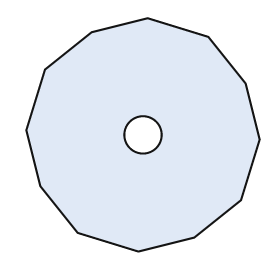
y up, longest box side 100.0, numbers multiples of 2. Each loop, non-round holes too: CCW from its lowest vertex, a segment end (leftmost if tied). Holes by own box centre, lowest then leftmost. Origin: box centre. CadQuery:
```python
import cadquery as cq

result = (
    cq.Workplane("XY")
    .moveTo(-2.0, -50.0)
    .lineTo(22.0, -44.0)
    .lineTo(42.0, -28.0)
    .lineTo(50.0, -2.0)
    .lineTo(44.0, 22.0)
    .lineTo(28.0, 42.0)
    .lineTo(2.0, 50.0)
    .lineTo(-22.0, 44.0)
    .lineTo(-42.0, 28.0)
    .lineTo(-50.0, 2.0)
    .lineTo(-44.0, -22.0)
    .lineTo(-28.0, -42.0)
    .close()
    .moveTo(0.0, 0.0)
    .circle(8.0)
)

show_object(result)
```